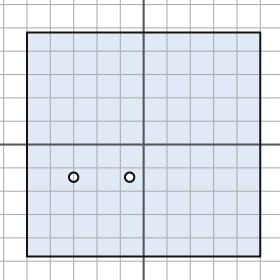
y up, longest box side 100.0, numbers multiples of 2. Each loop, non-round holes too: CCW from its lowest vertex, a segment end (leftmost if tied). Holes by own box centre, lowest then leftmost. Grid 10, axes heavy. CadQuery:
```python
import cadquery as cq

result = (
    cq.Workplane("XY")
    .moveTo(-50.0, -48.0)
    .lineTo(50.0, -48.0)
    .lineTo(50.0, 48.0)
    .lineTo(-50.0, 48.0)
    .close()
    .moveTo(-30.0, -14.0)
    .circle(2.0)
    .moveTo(-6.0, -14.0)
    .circle(2.0)
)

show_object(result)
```